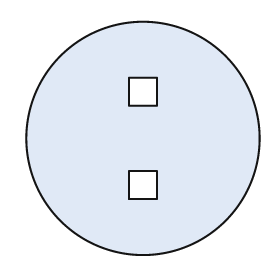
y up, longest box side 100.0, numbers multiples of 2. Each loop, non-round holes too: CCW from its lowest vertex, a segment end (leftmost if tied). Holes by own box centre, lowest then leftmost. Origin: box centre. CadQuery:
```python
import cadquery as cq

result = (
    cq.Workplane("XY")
    .moveTo(0.0, 0.0)
    .circle(50.0)
    .moveTo(-6.0, -26.0)
    .lineTo(6.0, -26.0)
    .lineTo(6.0, -14.0)
    .lineTo(-6.0, -14.0)
    .close()
    .moveTo(-6.0, 14.0)
    .lineTo(6.0, 14.0)
    .lineTo(6.0, 26.0)
    .lineTo(-6.0, 26.0)
    .close()
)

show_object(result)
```